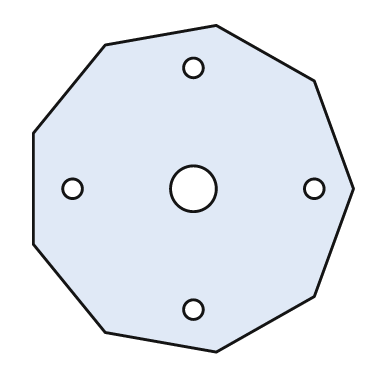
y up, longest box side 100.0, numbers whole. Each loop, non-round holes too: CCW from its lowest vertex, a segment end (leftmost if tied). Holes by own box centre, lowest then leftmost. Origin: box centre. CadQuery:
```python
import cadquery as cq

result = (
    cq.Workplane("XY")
    .moveTo(7.0, -50.0)
    .lineTo(37.0, -33.0)
    .lineTo(49.0, 0.0)
    .lineTo(37.0, 33.0)
    .lineTo(7.0, 50.0)
    .lineTo(-27.0, 44.0)
    .lineTo(-49.0, 17.0)
    .lineTo(-49.0, -17.0)
    .lineTo(-27.0, -44.0)
    .close()
    .moveTo(0.0, -37.0)
    .circle(3.0)
    .moveTo(-37.0, 0.0)
    .circle(3.0)
    .moveTo(0.0, 0.0)
    .circle(7.0)
    .moveTo(37.0, 0.0)
    .circle(3.0)
    .moveTo(0.0, 37.0)
    .circle(3.0)
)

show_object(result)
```